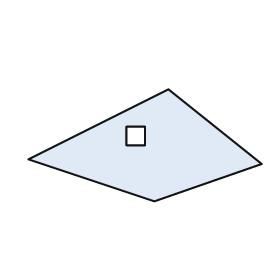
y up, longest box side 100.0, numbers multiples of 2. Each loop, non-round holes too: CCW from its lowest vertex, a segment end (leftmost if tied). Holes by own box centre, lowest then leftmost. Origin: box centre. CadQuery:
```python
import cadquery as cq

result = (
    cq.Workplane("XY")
    .moveTo(4.0, -24.0)
    .lineTo(50.0, -8.0)
    .lineTo(10.0, 24.0)
    .lineTo(-50.0, -6.0)
    .close()
    .moveTo(-8.0, 0.0)
    .lineTo(0.0, 0.0)
    .lineTo(0.0, 8.0)
    .lineTo(-8.0, 8.0)
    .close()
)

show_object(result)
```